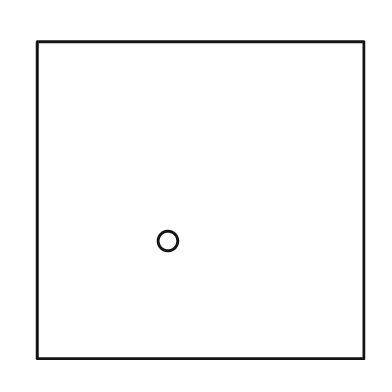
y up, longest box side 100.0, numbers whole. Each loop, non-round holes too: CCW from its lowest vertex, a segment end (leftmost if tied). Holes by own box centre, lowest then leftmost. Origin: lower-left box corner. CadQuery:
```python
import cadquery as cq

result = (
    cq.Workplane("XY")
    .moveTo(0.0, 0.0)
    .lineTo(100.0, 0.0)
    .lineTo(100.0, 97.0)
    .lineTo(0.0, 97.0)
    .close()
    .moveTo(40.0, 36.0)
    .circle(3.0)
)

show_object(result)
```